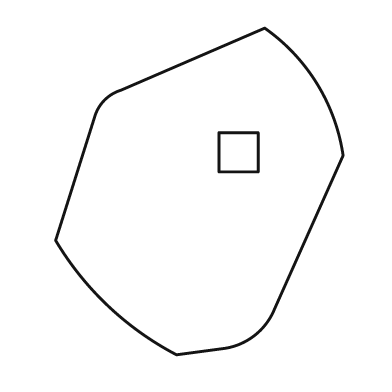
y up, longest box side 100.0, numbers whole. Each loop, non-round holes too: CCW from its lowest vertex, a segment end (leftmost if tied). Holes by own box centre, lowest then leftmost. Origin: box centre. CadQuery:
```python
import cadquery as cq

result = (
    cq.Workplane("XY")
    .moveTo(-7.0, -50.0)
    .lineTo(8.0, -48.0)
    .threePointArc((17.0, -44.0), (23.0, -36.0))
    .lineTo(44.0, 11.0)
    .threePointArc((36.0, 33.0), (20.0, 50.0))
    .lineTo(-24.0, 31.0)
    .threePointArc((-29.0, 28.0), (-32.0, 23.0))
    .lineTo(-44.0, -15.0)
    .threePointArc((-28.0, -35.0), (-7.0, -50.0))
    .close()
    .moveTo(6.0, 6.0)
    .lineTo(18.0, 6.0)
    .lineTo(18.0, 18.0)
    .lineTo(6.0, 18.0)
    .close()
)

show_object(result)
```